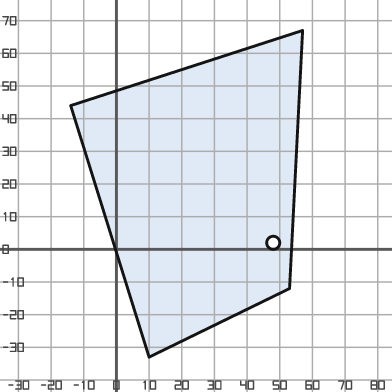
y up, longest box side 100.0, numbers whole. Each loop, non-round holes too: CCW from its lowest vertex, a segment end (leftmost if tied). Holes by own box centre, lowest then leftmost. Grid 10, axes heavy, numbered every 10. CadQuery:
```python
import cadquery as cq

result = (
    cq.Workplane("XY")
    .moveTo(10.0, -33.0)
    .lineTo(53.0, -12.0)
    .lineTo(57.0, 67.0)
    .lineTo(-14.0, 44.0)
    .close()
    .moveTo(48.0, 2.0)
    .circle(2.0)
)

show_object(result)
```